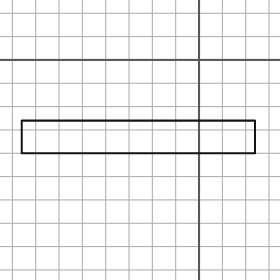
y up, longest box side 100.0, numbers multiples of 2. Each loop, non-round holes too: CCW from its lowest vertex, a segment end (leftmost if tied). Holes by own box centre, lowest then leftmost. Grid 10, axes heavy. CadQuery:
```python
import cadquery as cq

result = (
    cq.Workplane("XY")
    .moveTo(-76.0, -40.0)
    .lineTo(24.0, -40.0)
    .lineTo(24.0, -26.0)
    .lineTo(-76.0, -26.0)
    .close()
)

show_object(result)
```